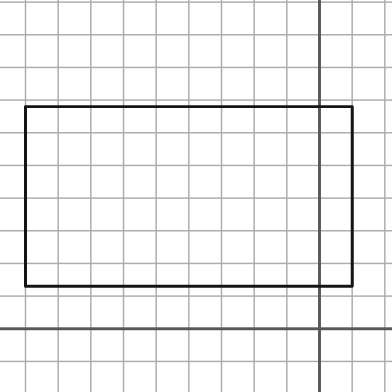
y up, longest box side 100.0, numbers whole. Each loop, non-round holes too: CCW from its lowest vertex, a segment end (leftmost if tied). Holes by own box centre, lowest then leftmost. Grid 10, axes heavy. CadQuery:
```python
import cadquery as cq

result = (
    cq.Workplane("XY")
    .moveTo(-90.0, 13.0)
    .lineTo(10.0, 13.0)
    .lineTo(10.0, 68.0)
    .lineTo(-90.0, 68.0)
    .close()
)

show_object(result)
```